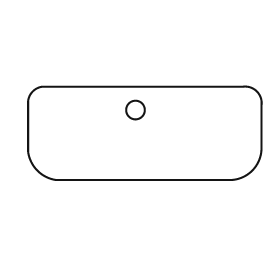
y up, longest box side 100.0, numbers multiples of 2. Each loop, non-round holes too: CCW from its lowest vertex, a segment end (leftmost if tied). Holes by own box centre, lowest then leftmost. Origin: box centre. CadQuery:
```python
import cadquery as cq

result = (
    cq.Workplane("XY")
    .moveTo(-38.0, -20.0)
    .lineTo(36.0, -20.0)
    .threePointArc((46.0, -16.0), (50.0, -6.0))
    .lineTo(50.0, 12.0)
    .threePointArc((48.0, 18.0), (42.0, 20.0))
    .lineTo(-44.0, 20.0)
    .threePointArc((-48.0, 18.0), (-50.0, 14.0))
    .lineTo(-50.0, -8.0)
    .threePointArc((-46.0, -16.0), (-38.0, -20.0))
    .close()
    .moveTo(-4.0, 10.0)
    .circle(4.0)
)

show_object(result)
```